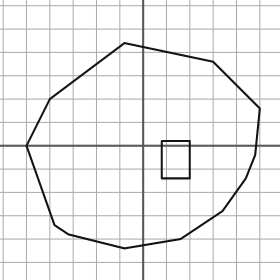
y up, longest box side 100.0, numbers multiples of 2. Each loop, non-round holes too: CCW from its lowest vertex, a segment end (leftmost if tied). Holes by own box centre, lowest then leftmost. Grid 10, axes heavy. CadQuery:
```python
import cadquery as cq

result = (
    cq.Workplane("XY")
    .moveTo(-8.0, -44.0)
    .lineTo(16.0, -40.0)
    .lineTo(34.0, -28.0)
    .lineTo(44.0, -14.0)
    .lineTo(48.0, -4.0)
    .lineTo(50.0, 16.0)
    .lineTo(30.0, 36.0)
    .lineTo(-8.0, 44.0)
    .lineTo(-40.0, 20.0)
    .lineTo(-50.0, 0.0)
    .lineTo(-38.0, -34.0)
    .lineTo(-32.0, -38.0)
    .close()
    .moveTo(8.0, -14.0)
    .lineTo(20.0, -14.0)
    .lineTo(20.0, 2.0)
    .lineTo(8.0, 2.0)
    .close()
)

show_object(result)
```